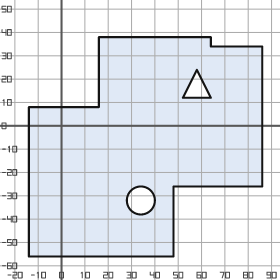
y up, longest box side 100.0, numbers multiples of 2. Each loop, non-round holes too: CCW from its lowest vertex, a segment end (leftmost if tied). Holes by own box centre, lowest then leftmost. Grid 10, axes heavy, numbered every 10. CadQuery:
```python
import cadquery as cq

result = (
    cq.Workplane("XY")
    .moveTo(-14.0, -56.0)
    .lineTo(48.0, -56.0)
    .lineTo(48.0, -26.0)
    .lineTo(86.0, -26.0)
    .lineTo(86.0, 34.0)
    .lineTo(64.0, 34.0)
    .lineTo(64.0, 38.0)
    .lineTo(16.0, 38.0)
    .lineTo(16.0, 8.0)
    .lineTo(-14.0, 8.0)
    .close()
    .moveTo(34.0, -32.0)
    .circle(6.0)
    .moveTo(52.0, 12.0)
    .lineTo(64.0, 12.0)
    .lineTo(58.0, 24.0)
    .close()
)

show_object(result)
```